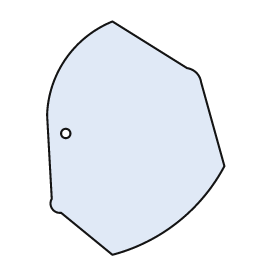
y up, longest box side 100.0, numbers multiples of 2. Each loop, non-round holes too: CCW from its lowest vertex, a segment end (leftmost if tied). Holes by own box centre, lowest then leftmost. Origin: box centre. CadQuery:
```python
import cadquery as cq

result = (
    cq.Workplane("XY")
    .moveTo(-10.0, -50.0)
    .threePointArc((18.0, -36.0), (38.0, -12.0))
    .lineTo(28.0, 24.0)
    .threePointArc((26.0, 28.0), (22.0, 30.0))
    .lineTo(-10.0, 50.0)
    .threePointArc((-30.0, 34.0), (-38.0, 10.0))
    .lineTo(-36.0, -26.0)
    .threePointArc((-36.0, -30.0), (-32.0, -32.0))
    .close()
    .moveTo(-30.0, 2.0)
    .circle(2.0)
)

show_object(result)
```